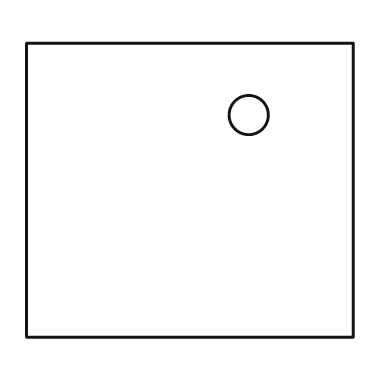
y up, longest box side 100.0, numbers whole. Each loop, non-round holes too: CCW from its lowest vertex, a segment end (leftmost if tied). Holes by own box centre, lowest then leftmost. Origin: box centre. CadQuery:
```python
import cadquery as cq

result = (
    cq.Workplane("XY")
    .moveTo(-50.0, -45.0)
    .lineTo(50.0, -45.0)
    .lineTo(50.0, 45.0)
    .lineTo(-50.0, 45.0)
    .close()
    .moveTo(18.0, 23.0)
    .circle(6.0)
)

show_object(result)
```